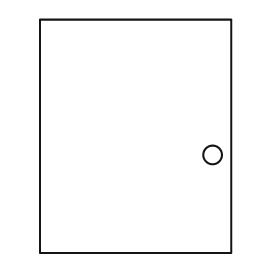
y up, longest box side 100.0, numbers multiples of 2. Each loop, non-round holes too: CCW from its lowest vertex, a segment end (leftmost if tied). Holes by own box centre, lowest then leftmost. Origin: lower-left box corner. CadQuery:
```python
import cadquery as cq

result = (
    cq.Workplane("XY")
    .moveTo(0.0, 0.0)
    .lineTo(82.0, 0.0)
    .lineTo(82.0, 100.0)
    .lineTo(0.0, 100.0)
    .close()
    .moveTo(74.0, 42.0)
    .circle(4.0)
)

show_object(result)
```